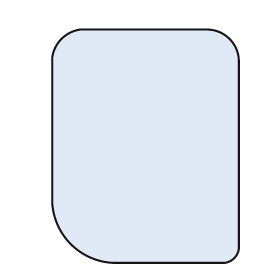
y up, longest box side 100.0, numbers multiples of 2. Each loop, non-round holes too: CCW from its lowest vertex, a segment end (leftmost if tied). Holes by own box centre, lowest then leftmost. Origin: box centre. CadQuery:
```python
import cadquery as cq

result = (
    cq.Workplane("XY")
    .moveTo(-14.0, -50.0)
    .lineTo(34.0, -50.0)
    .threePointArc((38.0, -48.0), (40.0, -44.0))
    .lineTo(40.0, 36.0)
    .threePointArc((36.0, 46.0), (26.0, 50.0))
    .lineTo(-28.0, 50.0)
    .threePointArc((-36.0, 46.0), (-40.0, 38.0))
    .lineTo(-40.0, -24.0)
    .threePointArc((-32.0, -42.0), (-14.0, -50.0))
    .close()
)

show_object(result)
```